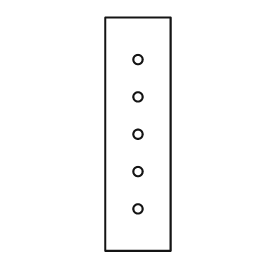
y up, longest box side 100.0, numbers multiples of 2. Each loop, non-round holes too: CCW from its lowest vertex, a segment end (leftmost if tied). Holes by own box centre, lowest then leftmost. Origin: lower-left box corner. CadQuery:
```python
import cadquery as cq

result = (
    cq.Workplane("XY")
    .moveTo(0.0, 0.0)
    .lineTo(28.0, 0.0)
    .lineTo(28.0, 100.0)
    .lineTo(0.0, 100.0)
    .close()
    .moveTo(14.0, 18.0)
    .circle(2.0)
    .moveTo(14.0, 34.0)
    .circle(2.0)
    .moveTo(14.0, 50.0)
    .circle(2.0)
    .moveTo(14.0, 66.0)
    .circle(2.0)
    .moveTo(14.0, 82.0)
    .circle(2.0)
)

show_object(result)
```